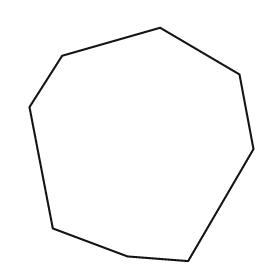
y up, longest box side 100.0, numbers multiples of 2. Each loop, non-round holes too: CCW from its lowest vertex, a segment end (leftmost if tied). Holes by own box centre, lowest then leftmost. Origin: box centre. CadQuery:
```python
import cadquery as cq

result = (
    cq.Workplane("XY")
    .moveTo(20.0, -50.0)
    .lineTo(48.0, -2.0)
    .lineTo(42.0, 30.0)
    .lineTo(8.0, 50.0)
    .lineTo(-34.0, 38.0)
    .lineTo(-48.0, 16.0)
    .lineTo(-38.0, -36.0)
    .lineTo(-6.0, -48.0)
    .close()
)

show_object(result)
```